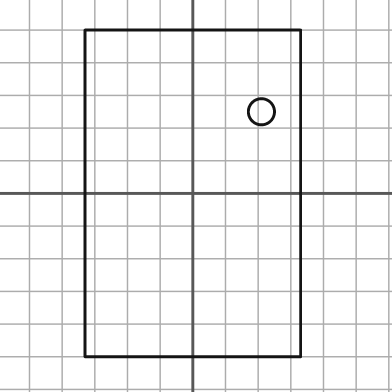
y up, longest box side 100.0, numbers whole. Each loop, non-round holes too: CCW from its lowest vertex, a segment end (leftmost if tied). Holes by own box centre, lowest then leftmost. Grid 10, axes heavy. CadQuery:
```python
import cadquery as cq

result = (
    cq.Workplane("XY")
    .moveTo(-33.0, -50.0)
    .lineTo(33.0, -50.0)
    .lineTo(33.0, 50.0)
    .lineTo(-33.0, 50.0)
    .close()
    .moveTo(21.0, 25.0)
    .circle(4.0)
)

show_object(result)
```